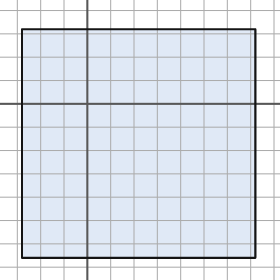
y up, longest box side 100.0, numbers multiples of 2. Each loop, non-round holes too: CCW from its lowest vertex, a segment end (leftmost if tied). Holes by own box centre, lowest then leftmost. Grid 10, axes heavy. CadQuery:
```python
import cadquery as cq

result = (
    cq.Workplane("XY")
    .moveTo(-28.0, -66.0)
    .lineTo(72.0, -66.0)
    .lineTo(72.0, 32.0)
    .lineTo(-28.0, 32.0)
    .close()
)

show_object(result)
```